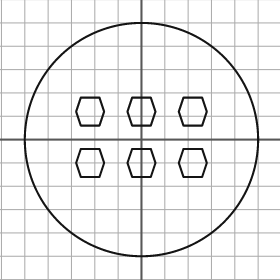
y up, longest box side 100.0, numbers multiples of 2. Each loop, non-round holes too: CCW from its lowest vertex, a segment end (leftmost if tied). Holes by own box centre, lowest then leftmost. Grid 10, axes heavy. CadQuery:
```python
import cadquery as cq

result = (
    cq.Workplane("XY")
    .moveTo(0.0, 0.0)
    .circle(50.0)
    .moveTo(-26.0, -16.0)
    .lineTo(-18.0, -16.0)
    .lineTo(-16.0, -10.0)
    .lineTo(-18.0, -4.0)
    .lineTo(-26.0, -4.0)
    .lineTo(-28.0, -10.0)
    .close()
    .moveTo(-4.0, -16.0)
    .lineTo(4.0, -16.0)
    .lineTo(6.0, -10.0)
    .lineTo(4.0, -4.0)
    .lineTo(-4.0, -4.0)
    .lineTo(-6.0, -10.0)
    .close()
    .moveTo(18.0, -16.0)
    .lineTo(26.0, -16.0)
    .lineTo(28.0, -10.0)
    .lineTo(26.0, -4.0)
    .lineTo(18.0, -4.0)
    .lineTo(16.0, -10.0)
    .close()
    .moveTo(-26.0, 6.0)
    .lineTo(-18.0, 6.0)
    .lineTo(-16.0, 12.0)
    .lineTo(-18.0, 18.0)
    .lineTo(-26.0, 18.0)
    .lineTo(-28.0, 12.0)
    .close()
    .moveTo(-4.0, 6.0)
    .lineTo(4.0, 6.0)
    .lineTo(6.0, 12.0)
    .lineTo(4.0, 18.0)
    .lineTo(-4.0, 18.0)
    .lineTo(-6.0, 12.0)
    .close()
    .moveTo(18.0, 6.0)
    .lineTo(26.0, 6.0)
    .lineTo(28.0, 12.0)
    .lineTo(26.0, 18.0)
    .lineTo(18.0, 18.0)
    .lineTo(16.0, 12.0)
    .close()
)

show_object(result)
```